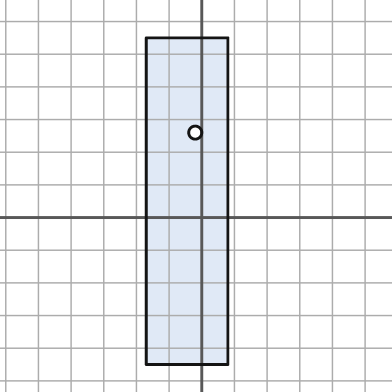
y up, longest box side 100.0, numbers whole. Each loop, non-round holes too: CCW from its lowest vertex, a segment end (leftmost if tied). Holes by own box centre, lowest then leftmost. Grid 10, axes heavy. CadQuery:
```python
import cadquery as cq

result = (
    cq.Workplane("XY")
    .moveTo(-17.0, -45.0)
    .lineTo(8.0, -45.0)
    .lineTo(8.0, 55.0)
    .lineTo(-17.0, 55.0)
    .close()
    .moveTo(-2.0, 26.0)
    .circle(2.0)
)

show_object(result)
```